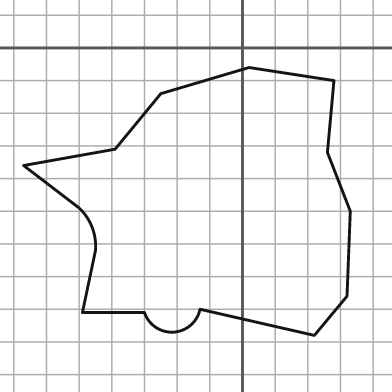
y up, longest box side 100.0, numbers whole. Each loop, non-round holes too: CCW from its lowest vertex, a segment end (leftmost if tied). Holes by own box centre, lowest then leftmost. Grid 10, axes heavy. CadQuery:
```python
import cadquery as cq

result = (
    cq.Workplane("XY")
    .moveTo(22.0, -88.0)
    .lineTo(32.0, -76.0)
    .lineTo(33.0, -50.0)
    .lineTo(26.0, -32.0)
    .lineTo(28.0, -10.0)
    .lineTo(2.0, -6.0)
    .lineTo(-25.0, -14.0)
    .lineTo(-39.0, -31.0)
    .lineTo(-67.0, -36.0)
    .lineTo(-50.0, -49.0)
    .threePointArc((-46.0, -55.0), (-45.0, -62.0))
    .lineTo(-49.0, -81.0)
    .lineTo(-30.0, -81.0)
    .threePointArc((-21.0, -87.0), (-13.0, -80.0))
    .close()
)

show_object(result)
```